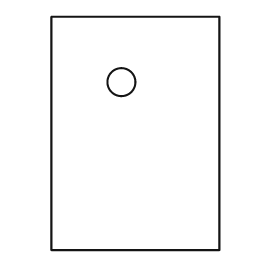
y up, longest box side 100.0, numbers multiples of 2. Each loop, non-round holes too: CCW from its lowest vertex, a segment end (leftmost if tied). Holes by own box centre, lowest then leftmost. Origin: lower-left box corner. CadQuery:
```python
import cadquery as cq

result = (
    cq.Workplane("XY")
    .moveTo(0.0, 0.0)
    .lineTo(72.0, 0.0)
    .lineTo(72.0, 100.0)
    .lineTo(0.0, 100.0)
    .close()
    .moveTo(30.0, 72.0)
    .circle(6.0)
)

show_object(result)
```